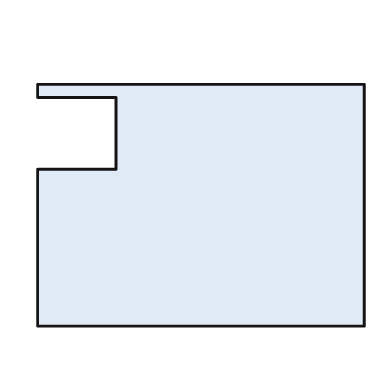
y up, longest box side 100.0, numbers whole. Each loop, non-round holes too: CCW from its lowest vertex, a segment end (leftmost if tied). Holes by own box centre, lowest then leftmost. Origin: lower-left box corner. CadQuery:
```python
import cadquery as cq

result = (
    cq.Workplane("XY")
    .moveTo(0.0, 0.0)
    .lineTo(100.0, 0.0)
    .lineTo(100.0, 74.0)
    .lineTo(0.0, 74.0)
    .lineTo(0.0, 70.0)
    .lineTo(24.0, 70.0)
    .lineTo(24.0, 48.0)
    .lineTo(0.0, 48.0)
    .close()
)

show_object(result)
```